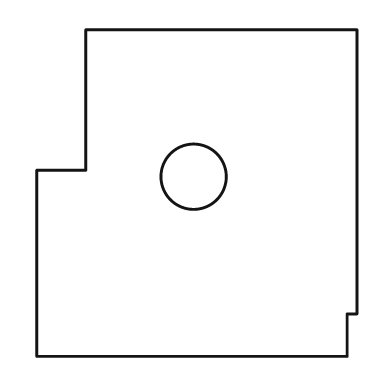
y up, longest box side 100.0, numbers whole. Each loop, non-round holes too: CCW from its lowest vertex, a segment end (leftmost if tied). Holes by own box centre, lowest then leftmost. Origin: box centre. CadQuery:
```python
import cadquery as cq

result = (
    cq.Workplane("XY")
    .moveTo(-49.0, -50.0)
    .lineTo(46.0, -50.0)
    .lineTo(46.0, -37.0)
    .lineTo(49.0, -37.0)
    .lineTo(49.0, 50.0)
    .lineTo(-34.0, 50.0)
    .lineTo(-34.0, 7.0)
    .lineTo(-49.0, 7.0)
    .close()
    .moveTo(-1.0, 5.0)
    .circle(10.0)
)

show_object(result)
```